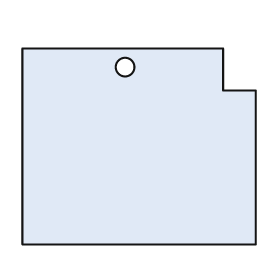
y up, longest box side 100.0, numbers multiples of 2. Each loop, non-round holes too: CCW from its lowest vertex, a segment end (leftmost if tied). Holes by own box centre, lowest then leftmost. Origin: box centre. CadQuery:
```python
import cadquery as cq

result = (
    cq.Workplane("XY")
    .moveTo(-50.0, -42.0)
    .lineTo(50.0, -42.0)
    .lineTo(50.0, 24.0)
    .lineTo(36.0, 24.0)
    .lineTo(36.0, 42.0)
    .lineTo(-50.0, 42.0)
    .close()
    .moveTo(-6.0, 34.0)
    .circle(4.0)
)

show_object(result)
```